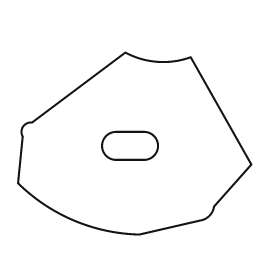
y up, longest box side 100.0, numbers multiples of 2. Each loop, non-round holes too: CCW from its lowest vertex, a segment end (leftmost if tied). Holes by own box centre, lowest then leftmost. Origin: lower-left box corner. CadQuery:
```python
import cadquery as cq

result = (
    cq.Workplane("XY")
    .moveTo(52.0, 0.0)
    .lineTo(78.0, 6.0)
    .threePointArc((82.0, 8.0), (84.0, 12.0))
    .lineTo(100.0, 30.0)
    .lineTo(74.0, 76.0)
    .threePointArc((60.0, 74.0), (46.0, 78.0))
    .lineTo(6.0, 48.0)
    .threePointArc((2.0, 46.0), (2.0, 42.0))
    .lineTo(0.0, 22.0)
    .threePointArc((24.0, 6.0), (52.0, 0.0))
    .close()
    .moveTo(42.0, 32.0)
    .lineTo(54.0, 32.0)
    .threePointArc((60.0, 38.0), (54.0, 44.0))
    .lineTo(42.0, 44.0)
    .threePointArc((36.0, 38.0), (42.0, 32.0))
    .close()
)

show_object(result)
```